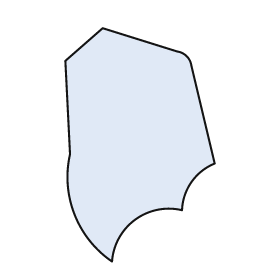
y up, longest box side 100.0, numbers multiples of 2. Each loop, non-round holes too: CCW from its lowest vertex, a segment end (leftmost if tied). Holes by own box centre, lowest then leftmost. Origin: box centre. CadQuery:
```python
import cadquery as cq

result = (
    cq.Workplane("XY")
    .moveTo(-12.0, -50.0)
    .threePointArc((-2.0, -32.0), (18.0, -28.0))
    .threePointArc((22.0, -16.0), (32.0, -8.0))
    .lineTo(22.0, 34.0)
    .threePointArc((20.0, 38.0), (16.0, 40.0))
    .lineTo(-16.0, 50.0)
    .lineTo(-32.0, 36.0)
    .lineTo(-30.0, -4.0)
    .threePointArc((-28.0, -30.0), (-12.0, -50.0))
    .close()
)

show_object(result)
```